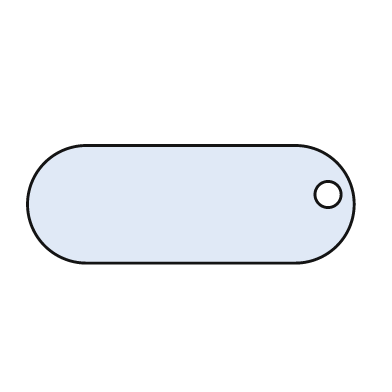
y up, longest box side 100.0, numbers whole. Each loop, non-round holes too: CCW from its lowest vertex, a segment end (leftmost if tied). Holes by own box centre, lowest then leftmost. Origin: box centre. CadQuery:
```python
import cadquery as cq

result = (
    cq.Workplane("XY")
    .moveTo(-32.0, -18.0)
    .lineTo(32.0, -18.0)
    .threePointArc((50.0, 0.0), (32.0, 18.0))
    .lineTo(-32.0, 18.0)
    .threePointArc((-50.0, 0.0), (-32.0, -18.0))
    .close()
    .moveTo(42.0, 3.0)
    .circle(4.0)
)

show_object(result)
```